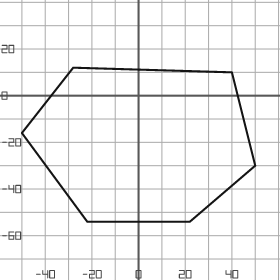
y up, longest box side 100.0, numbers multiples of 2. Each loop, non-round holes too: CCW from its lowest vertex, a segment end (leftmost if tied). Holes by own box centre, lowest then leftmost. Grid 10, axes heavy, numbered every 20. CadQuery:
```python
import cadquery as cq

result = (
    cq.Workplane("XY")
    .moveTo(-22.0, -54.0)
    .lineTo(22.0, -54.0)
    .lineTo(50.0, -30.0)
    .lineTo(40.0, 10.0)
    .lineTo(-28.0, 12.0)
    .lineTo(-50.0, -16.0)
    .close()
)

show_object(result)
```